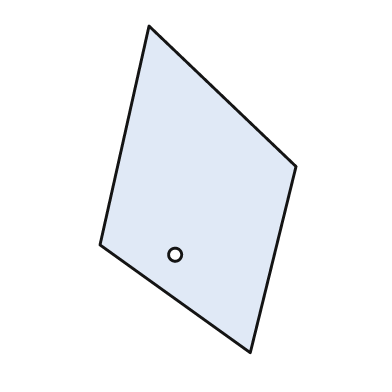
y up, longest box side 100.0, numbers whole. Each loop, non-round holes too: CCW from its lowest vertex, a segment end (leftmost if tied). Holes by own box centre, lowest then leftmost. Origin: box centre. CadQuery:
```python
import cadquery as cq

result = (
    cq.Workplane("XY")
    .moveTo(16.0, -50.0)
    .lineTo(30.0, 7.0)
    .lineTo(-15.0, 50.0)
    .lineTo(-30.0, -17.0)
    .close()
    .moveTo(-7.0, -20.0)
    .circle(2.0)
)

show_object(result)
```